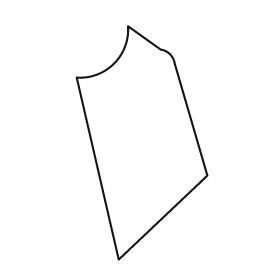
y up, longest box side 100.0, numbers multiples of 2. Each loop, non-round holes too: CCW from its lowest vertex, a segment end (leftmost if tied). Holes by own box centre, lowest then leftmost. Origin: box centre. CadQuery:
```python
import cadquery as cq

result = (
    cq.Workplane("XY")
    .moveTo(-10.0, -50.0)
    .lineTo(28.0, -14.0)
    .lineTo(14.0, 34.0)
    .threePointArc((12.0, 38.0), (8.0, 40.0))
    .lineTo(-6.0, 50.0)
    .threePointArc((-12.0, 34.0), (-28.0, 28.0))
    .close()
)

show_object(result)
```